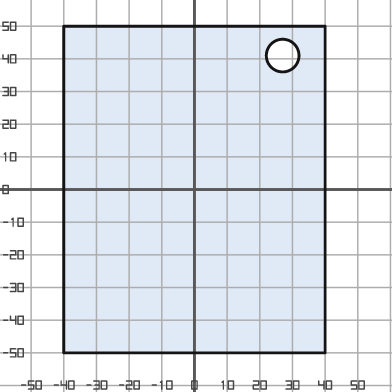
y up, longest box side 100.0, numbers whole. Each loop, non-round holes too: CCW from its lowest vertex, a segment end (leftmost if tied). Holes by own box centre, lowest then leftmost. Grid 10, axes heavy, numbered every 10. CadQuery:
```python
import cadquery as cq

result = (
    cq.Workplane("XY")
    .moveTo(-40.0, -50.0)
    .lineTo(40.0, -50.0)
    .lineTo(40.0, 50.0)
    .lineTo(-40.0, 50.0)
    .close()
    .moveTo(27.0, 41.0)
    .circle(5.0)
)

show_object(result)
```